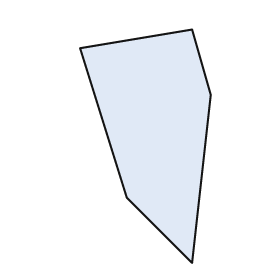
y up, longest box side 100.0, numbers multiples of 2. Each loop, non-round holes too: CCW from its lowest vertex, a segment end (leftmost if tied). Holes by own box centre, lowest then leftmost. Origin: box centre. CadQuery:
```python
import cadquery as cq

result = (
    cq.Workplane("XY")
    .moveTo(20.0, -50.0)
    .lineTo(28.0, 22.0)
    .lineTo(20.0, 50.0)
    .lineTo(-28.0, 42.0)
    .lineTo(-8.0, -22.0)
    .close()
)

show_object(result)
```